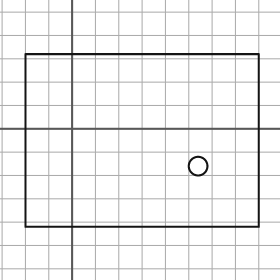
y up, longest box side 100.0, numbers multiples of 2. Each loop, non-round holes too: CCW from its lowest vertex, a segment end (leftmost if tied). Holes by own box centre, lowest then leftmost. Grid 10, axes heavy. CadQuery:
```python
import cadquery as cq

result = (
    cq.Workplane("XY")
    .moveTo(-20.0, -42.0)
    .lineTo(80.0, -42.0)
    .lineTo(80.0, 32.0)
    .lineTo(-20.0, 32.0)
    .close()
    .moveTo(54.0, -16.0)
    .circle(4.0)
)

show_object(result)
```